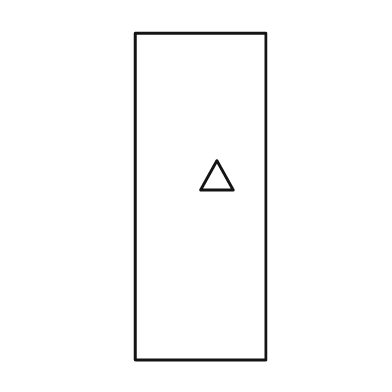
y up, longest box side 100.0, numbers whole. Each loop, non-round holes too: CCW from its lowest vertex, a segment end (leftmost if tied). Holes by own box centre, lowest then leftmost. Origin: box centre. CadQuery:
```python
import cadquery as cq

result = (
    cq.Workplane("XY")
    .moveTo(-20.0, -50.0)
    .lineTo(20.0, -50.0)
    .lineTo(20.0, 50.0)
    .lineTo(-20.0, 50.0)
    .close()
    .moveTo(0.0, 2.0)
    .lineTo(10.0, 2.0)
    .lineTo(5.0, 11.0)
    .close()
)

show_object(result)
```